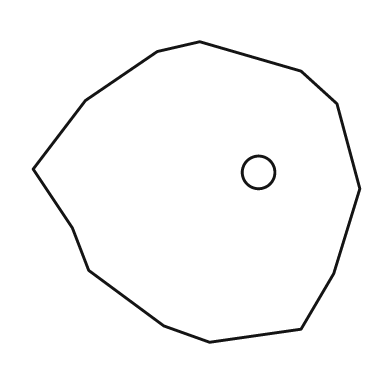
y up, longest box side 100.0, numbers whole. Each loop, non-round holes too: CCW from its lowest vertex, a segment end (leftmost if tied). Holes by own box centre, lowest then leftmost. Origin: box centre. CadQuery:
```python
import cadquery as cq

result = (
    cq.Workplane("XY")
    .moveTo(4.0, -46.0)
    .lineTo(32.0, -42.0)
    .lineTo(42.0, -25.0)
    .lineTo(50.0, 1.0)
    .lineTo(43.0, 27.0)
    .lineTo(32.0, 37.0)
    .lineTo(1.0, 46.0)
    .lineTo(-12.0, 43.0)
    .lineTo(-34.0, 28.0)
    .lineTo(-50.0, 7.0)
    .lineTo(-38.0, -11.0)
    .lineTo(-33.0, -24.0)
    .lineTo(-10.0, -41.0)
    .close()
    .moveTo(19.0, 6.0)
    .circle(5.0)
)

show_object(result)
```